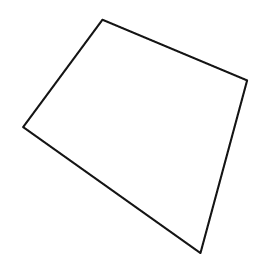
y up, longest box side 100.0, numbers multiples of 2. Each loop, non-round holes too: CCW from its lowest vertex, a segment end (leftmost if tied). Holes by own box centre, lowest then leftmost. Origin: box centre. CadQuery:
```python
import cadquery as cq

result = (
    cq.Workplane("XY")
    .moveTo(28.0, -50.0)
    .lineTo(48.0, 24.0)
    .lineTo(-14.0, 50.0)
    .lineTo(-48.0, 4.0)
    .close()
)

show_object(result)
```